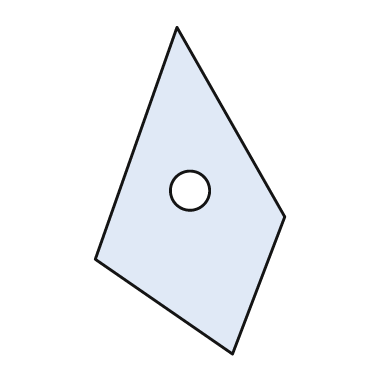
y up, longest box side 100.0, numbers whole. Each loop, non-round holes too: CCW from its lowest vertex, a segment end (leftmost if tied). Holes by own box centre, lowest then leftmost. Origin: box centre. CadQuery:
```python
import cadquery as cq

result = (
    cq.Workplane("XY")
    .moveTo(13.0, -50.0)
    .lineTo(29.0, -8.0)
    .lineTo(-4.0, 50.0)
    .lineTo(-29.0, -21.0)
    .close()
    .moveTo(0.0, 0.0)
    .circle(6.0)
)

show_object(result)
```